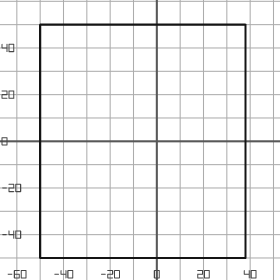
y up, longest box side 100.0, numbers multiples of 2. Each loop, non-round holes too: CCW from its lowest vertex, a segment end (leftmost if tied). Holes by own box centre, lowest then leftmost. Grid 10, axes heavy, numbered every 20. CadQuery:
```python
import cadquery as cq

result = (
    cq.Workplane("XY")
    .moveTo(-50.0, -50.0)
    .lineTo(38.0, -50.0)
    .lineTo(38.0, 50.0)
    .lineTo(-50.0, 50.0)
    .close()
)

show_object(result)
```